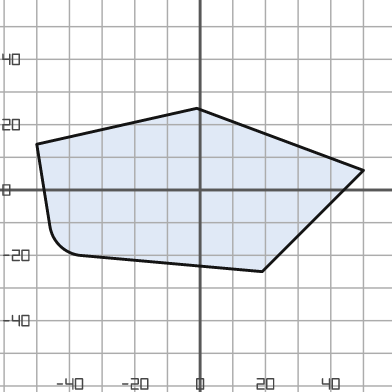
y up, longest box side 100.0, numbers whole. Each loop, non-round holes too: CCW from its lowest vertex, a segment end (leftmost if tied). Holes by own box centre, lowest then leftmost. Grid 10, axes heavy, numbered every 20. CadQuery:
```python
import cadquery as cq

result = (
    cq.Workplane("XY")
    .moveTo(19.0, -25.0)
    .lineTo(50.0, 6.0)
    .lineTo(-1.0, 25.0)
    .lineTo(-50.0, 14.0)
    .lineTo(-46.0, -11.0)
    .threePointArc((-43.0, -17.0), (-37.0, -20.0))
    .close()
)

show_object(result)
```